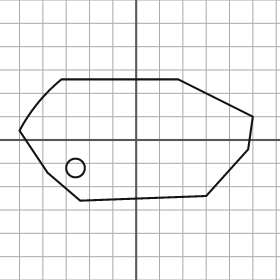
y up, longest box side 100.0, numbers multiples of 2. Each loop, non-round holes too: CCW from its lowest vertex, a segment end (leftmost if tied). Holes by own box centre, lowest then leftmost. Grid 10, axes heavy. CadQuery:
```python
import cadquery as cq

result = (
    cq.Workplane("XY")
    .moveTo(-24.0, -26.0)
    .lineTo(30.0, -24.0)
    .lineTo(48.0, -4.0)
    .lineTo(50.0, 10.0)
    .lineTo(18.0, 26.0)
    .lineTo(-32.0, 26.0)
    .threePointArc((-42.0, 16.0), (-50.0, 4.0))
    .lineTo(-38.0, -14.0)
    .close()
    .moveTo(-26.0, -12.0)
    .circle(4.0)
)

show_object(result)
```